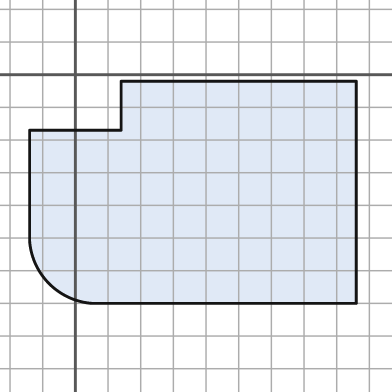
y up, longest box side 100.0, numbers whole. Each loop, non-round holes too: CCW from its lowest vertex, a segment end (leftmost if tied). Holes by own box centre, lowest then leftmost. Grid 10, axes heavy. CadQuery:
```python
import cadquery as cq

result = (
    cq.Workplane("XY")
    .moveTo(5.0, -70.0)
    .lineTo(86.0, -70.0)
    .lineTo(86.0, -2.0)
    .lineTo(14.0, -2.0)
    .lineTo(14.0, -17.0)
    .lineTo(-14.0, -17.0)
    .lineTo(-14.0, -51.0)
    .threePointArc((-8.0, -64.0), (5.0, -70.0))
    .close()
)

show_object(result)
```